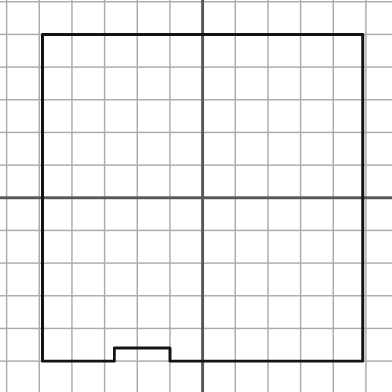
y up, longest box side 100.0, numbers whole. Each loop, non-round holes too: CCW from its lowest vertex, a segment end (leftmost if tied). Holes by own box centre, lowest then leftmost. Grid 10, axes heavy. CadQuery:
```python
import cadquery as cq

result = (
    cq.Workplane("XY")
    .moveTo(-49.0, -50.0)
    .lineTo(-27.0, -50.0)
    .lineTo(-27.0, -46.0)
    .lineTo(-10.0, -46.0)
    .lineTo(-10.0, -50.0)
    .lineTo(49.0, -50.0)
    .lineTo(49.0, 50.0)
    .lineTo(-49.0, 50.0)
    .close()
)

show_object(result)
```